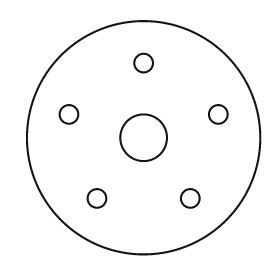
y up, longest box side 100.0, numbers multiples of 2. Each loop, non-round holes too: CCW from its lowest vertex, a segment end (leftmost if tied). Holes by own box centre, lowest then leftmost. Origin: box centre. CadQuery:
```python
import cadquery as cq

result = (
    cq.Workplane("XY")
    .moveTo(0.0, 0.0)
    .circle(50.0)
    .moveTo(-20.0, -26.0)
    .circle(4.0)
    .moveTo(20.0, -26.0)
    .circle(4.0)
    .moveTo(0.0, 0.0)
    .circle(10.0)
    .moveTo(-32.0, 10.0)
    .circle(4.0)
    .moveTo(32.0, 10.0)
    .circle(4.0)
    .moveTo(0.0, 32.0)
    .circle(4.0)
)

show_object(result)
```